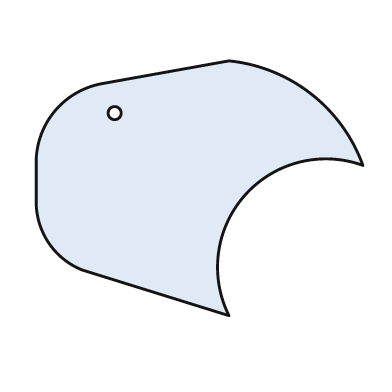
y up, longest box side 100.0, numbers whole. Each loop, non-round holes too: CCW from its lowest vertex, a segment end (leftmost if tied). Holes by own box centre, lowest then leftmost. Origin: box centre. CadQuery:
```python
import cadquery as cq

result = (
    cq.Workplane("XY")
    .moveTo(9.0, -39.0)
    .threePointArc((14.0, -2.0), (50.0, 7.0))
    .threePointArc((34.0, 29.0), (9.0, 39.0))
    .lineTo(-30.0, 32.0)
    .threePointArc((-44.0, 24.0), (-50.0, 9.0))
    .lineTo(-50.0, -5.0)
    .threePointArc((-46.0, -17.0), (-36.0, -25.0))
    .close()
    .moveTo(-26.0, 23.0)
    .circle(2.0)
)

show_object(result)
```